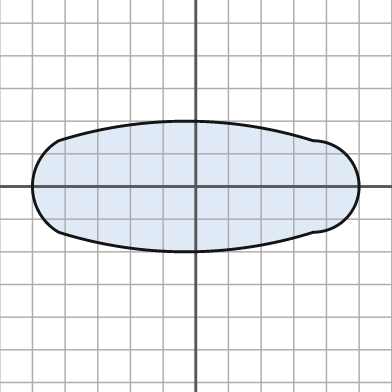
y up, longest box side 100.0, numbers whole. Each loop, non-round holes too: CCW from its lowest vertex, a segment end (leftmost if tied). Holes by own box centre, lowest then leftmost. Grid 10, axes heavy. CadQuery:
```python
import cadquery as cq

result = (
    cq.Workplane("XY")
    .moveTo(-42.0, -14.0)
    .threePointArc((-3.0, -20.0), (36.0, -14.0))
    .threePointArc((50.0, 0.0), (36.0, 14.0))
    .threePointArc((-3.0, 20.0), (-42.0, 14.0))
    .threePointArc((-50.0, 0.0), (-42.0, -14.0))
    .close()
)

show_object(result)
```